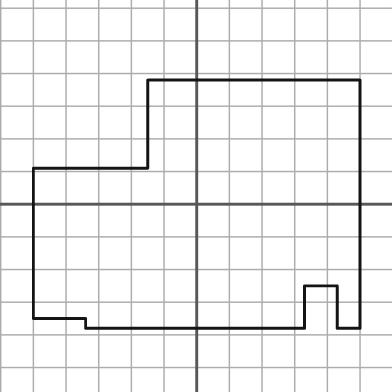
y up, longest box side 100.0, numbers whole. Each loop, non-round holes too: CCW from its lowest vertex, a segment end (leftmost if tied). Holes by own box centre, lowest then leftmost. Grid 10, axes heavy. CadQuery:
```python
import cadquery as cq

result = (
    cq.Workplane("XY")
    .moveTo(-34.0, -38.0)
    .lineTo(33.0, -38.0)
    .lineTo(33.0, -25.0)
    .lineTo(43.0, -25.0)
    .lineTo(43.0, -38.0)
    .lineTo(50.0, -38.0)
    .lineTo(50.0, 38.0)
    .lineTo(-15.0, 38.0)
    .lineTo(-15.0, 11.0)
    .lineTo(-50.0, 11.0)
    .lineTo(-50.0, -35.0)
    .lineTo(-34.0, -35.0)
    .close()
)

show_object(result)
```